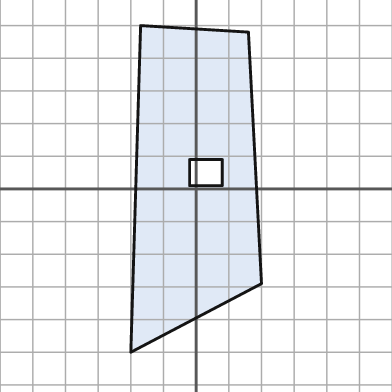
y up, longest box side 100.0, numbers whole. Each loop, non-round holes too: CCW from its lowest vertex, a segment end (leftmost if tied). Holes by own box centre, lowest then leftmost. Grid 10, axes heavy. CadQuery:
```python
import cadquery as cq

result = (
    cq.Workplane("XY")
    .moveTo(-20.0, -50.0)
    .lineTo(20.0, -29.0)
    .lineTo(16.0, 48.0)
    .lineTo(-17.0, 50.0)
    .close()
    .moveTo(-2.0, 1.0)
    .lineTo(8.0, 1.0)
    .lineTo(8.0, 9.0)
    .lineTo(-2.0, 9.0)
    .close()
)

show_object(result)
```